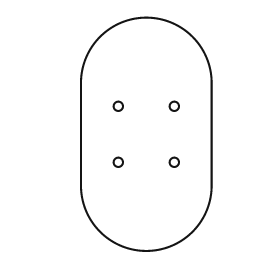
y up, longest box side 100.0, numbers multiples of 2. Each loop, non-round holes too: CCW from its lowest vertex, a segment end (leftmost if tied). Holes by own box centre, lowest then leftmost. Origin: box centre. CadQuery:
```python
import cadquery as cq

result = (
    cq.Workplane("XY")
    .moveTo(-28.0, -22.0)
    .threePointArc((0.0, -50.0), (28.0, -22.0))
    .lineTo(28.0, 22.0)
    .threePointArc((0.0, 50.0), (-28.0, 22.0))
    .close()
    .moveTo(-12.0, -12.0)
    .circle(2.0)
    .moveTo(12.0, -12.0)
    .circle(2.0)
    .moveTo(-12.0, 12.0)
    .circle(2.0)
    .moveTo(12.0, 12.0)
    .circle(2.0)
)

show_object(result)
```